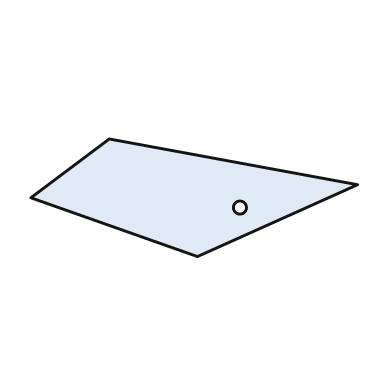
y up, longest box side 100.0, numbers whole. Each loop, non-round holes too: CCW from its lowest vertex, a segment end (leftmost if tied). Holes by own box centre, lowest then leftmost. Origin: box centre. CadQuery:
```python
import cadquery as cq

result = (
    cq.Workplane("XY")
    .moveTo(1.0, -18.0)
    .lineTo(50.0, 4.0)
    .lineTo(-26.0, 18.0)
    .lineTo(-50.0, 0.0)
    .close()
    .moveTo(14.0, -3.0)
    .circle(2.0)
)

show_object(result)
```